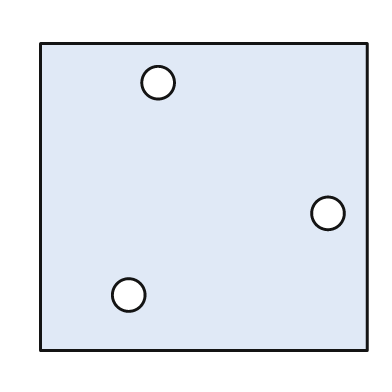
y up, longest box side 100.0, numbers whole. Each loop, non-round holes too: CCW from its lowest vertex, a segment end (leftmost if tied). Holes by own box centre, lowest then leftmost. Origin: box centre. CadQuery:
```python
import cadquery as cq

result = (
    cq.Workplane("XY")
    .moveTo(-50.0, -47.0)
    .lineTo(50.0, -47.0)
    .lineTo(50.0, 47.0)
    .lineTo(-50.0, 47.0)
    .close()
    .moveTo(-23.0, -30.0)
    .circle(5.0)
    .moveTo(38.0, -5.0)
    .circle(5.0)
    .moveTo(-14.0, 35.0)
    .circle(5.0)
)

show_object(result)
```